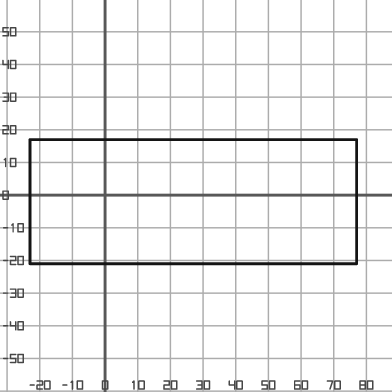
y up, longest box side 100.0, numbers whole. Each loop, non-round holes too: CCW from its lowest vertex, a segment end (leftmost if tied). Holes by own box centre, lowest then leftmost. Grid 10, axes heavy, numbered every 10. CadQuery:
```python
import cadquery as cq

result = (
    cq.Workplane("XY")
    .moveTo(-23.0, -21.0)
    .lineTo(77.0, -21.0)
    .lineTo(77.0, 17.0)
    .lineTo(-23.0, 17.0)
    .close()
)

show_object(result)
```